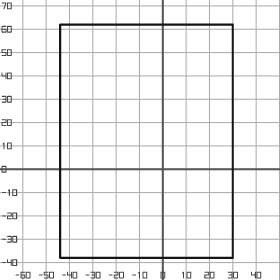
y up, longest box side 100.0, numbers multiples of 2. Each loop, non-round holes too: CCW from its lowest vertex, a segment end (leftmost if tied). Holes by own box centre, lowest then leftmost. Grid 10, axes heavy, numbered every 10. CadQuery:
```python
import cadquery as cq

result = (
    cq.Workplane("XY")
    .moveTo(-44.0, -38.0)
    .lineTo(30.0, -38.0)
    .lineTo(30.0, 62.0)
    .lineTo(-44.0, 62.0)
    .close()
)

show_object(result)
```